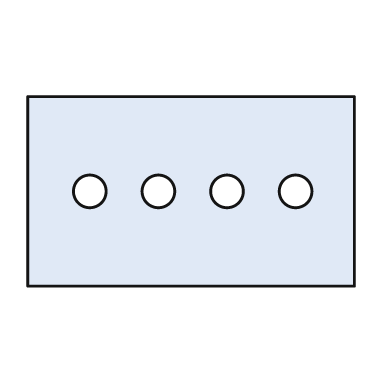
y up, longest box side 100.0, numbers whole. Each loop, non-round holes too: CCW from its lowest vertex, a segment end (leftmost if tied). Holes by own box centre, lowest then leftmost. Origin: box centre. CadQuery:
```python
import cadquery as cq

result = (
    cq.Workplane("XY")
    .moveTo(-50.0, -29.0)
    .lineTo(50.0, -29.0)
    .lineTo(50.0, 29.0)
    .lineTo(-50.0, 29.0)
    .close()
    .moveTo(-31.0, 0.0)
    .circle(5.0)
    .moveTo(-10.0, 0.0)
    .circle(5.0)
    .moveTo(11.0, 0.0)
    .circle(5.0)
    .moveTo(32.0, 0.0)
    .circle(5.0)
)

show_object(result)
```